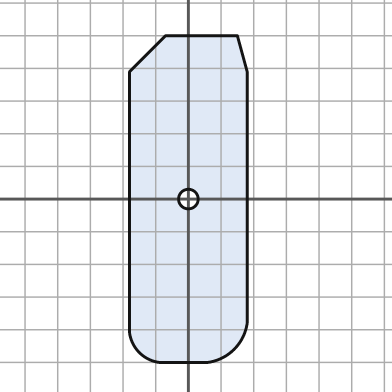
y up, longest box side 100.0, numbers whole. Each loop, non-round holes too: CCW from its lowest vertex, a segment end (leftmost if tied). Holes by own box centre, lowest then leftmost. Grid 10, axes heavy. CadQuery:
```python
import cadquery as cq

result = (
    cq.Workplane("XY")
    .moveTo(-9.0, -50.0)
    .lineTo(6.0, -50.0)
    .threePointArc((14.0, -46.0), (18.0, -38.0))
    .lineTo(18.0, 39.0)
    .lineTo(15.0, 50.0)
    .lineTo(-7.0, 50.0)
    .lineTo(-18.0, 39.0)
    .lineTo(-18.0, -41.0)
    .threePointArc((-15.0, -47.0), (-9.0, -50.0))
    .close()
    .moveTo(0.0, 0.0)
    .circle(3.0)
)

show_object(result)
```